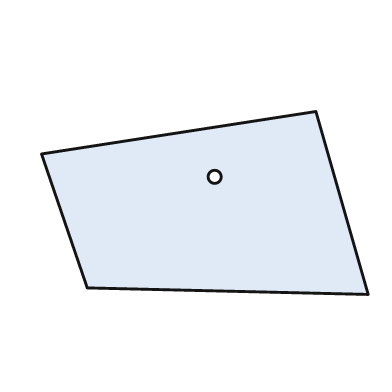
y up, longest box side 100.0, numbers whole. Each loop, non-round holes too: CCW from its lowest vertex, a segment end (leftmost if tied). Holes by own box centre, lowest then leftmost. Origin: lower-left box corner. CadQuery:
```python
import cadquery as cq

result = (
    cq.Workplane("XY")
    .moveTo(100.0, 0.0)
    .lineTo(84.0, 56.0)
    .lineTo(0.0, 43.0)
    .lineTo(14.0, 2.0)
    .close()
    .moveTo(53.0, 36.0)
    .circle(2.0)
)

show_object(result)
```